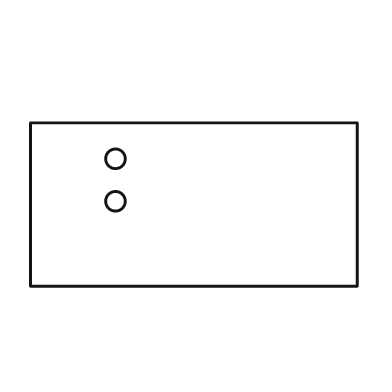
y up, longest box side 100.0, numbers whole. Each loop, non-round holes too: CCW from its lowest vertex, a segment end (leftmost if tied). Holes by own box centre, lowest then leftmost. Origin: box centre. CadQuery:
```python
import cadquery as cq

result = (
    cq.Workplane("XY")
    .moveTo(-50.0, -25.0)
    .lineTo(50.0, -25.0)
    .lineTo(50.0, 25.0)
    .lineTo(-50.0, 25.0)
    .close()
    .moveTo(-24.0, 1.0)
    .circle(3.0)
    .moveTo(-24.0, 14.0)
    .circle(3.0)
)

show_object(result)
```